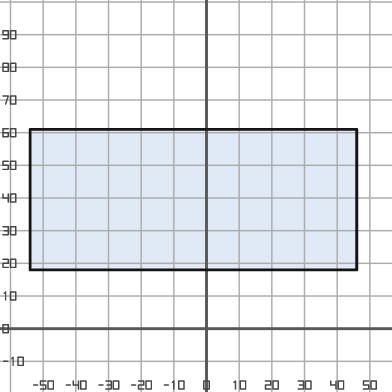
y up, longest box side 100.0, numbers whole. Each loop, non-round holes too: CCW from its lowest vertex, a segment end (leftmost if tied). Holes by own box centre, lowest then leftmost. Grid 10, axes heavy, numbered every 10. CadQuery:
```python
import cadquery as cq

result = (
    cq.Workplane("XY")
    .moveTo(-54.0, 18.0)
    .lineTo(46.0, 18.0)
    .lineTo(46.0, 61.0)
    .lineTo(-54.0, 61.0)
    .close()
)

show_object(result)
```